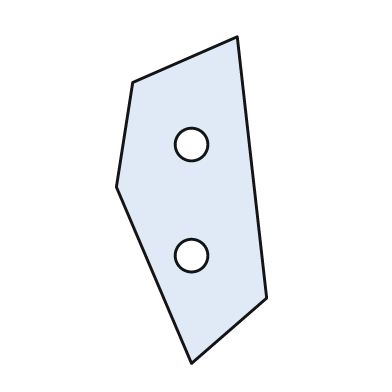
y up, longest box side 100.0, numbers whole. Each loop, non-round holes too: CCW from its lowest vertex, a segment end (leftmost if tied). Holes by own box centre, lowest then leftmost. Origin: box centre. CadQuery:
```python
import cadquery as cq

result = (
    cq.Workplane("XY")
    .moveTo(0.0, -50.0)
    .lineTo(23.0, -30.0)
    .lineTo(14.0, 50.0)
    .lineTo(-18.0, 36.0)
    .lineTo(-23.0, 4.0)
    .close()
    .moveTo(0.0, -17.0)
    .circle(5.0)
    .moveTo(0.0, 17.0)
    .circle(5.0)
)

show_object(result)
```